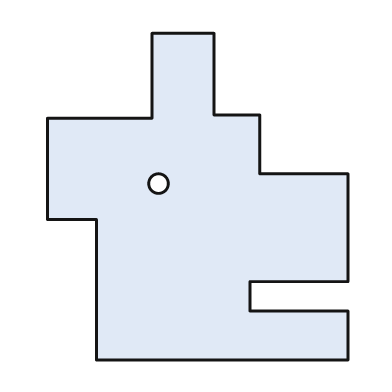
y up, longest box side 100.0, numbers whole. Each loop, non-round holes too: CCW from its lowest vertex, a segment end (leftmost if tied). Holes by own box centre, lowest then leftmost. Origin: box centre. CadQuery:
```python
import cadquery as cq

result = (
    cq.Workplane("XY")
    .moveTo(-31.0, -50.0)
    .lineTo(46.0, -50.0)
    .lineTo(46.0, -35.0)
    .lineTo(16.0, -35.0)
    .lineTo(16.0, -26.0)
    .lineTo(46.0, -26.0)
    .lineTo(46.0, 7.0)
    .lineTo(19.0, 7.0)
    .lineTo(19.0, 25.0)
    .lineTo(5.0, 25.0)
    .lineTo(5.0, 50.0)
    .lineTo(-14.0, 50.0)
    .lineTo(-14.0, 24.0)
    .lineTo(-46.0, 24.0)
    .lineTo(-46.0, -7.0)
    .lineTo(-31.0, -7.0)
    .close()
    .moveTo(-12.0, 4.0)
    .circle(3.0)
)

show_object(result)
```